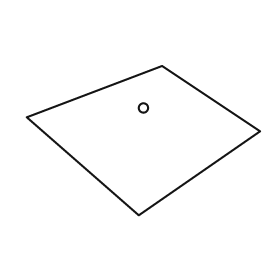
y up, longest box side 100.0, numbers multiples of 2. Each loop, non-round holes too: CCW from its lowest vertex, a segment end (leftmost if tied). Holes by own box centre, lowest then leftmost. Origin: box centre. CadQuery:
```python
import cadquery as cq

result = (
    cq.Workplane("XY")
    .moveTo(-2.0, -32.0)
    .lineTo(50.0, 4.0)
    .lineTo(8.0, 32.0)
    .lineTo(-50.0, 10.0)
    .close()
    .moveTo(0.0, 14.0)
    .circle(2.0)
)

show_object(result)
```